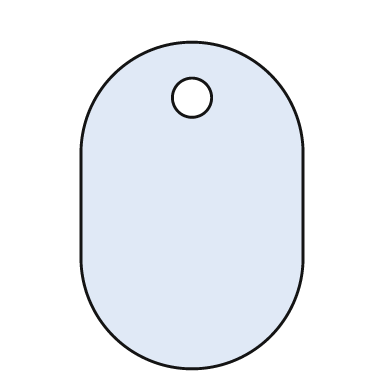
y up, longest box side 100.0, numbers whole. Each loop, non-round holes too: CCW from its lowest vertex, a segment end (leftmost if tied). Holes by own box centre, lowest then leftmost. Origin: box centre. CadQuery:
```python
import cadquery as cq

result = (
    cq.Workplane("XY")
    .moveTo(-34.0, -16.0)
    .threePointArc((0.0, -50.0), (34.0, -16.0))
    .lineTo(34.0, 16.0)
    .threePointArc((0.0, 50.0), (-34.0, 16.0))
    .close()
    .moveTo(0.0, 33.0)
    .circle(6.0)
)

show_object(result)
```